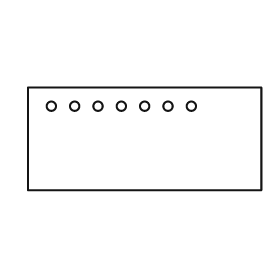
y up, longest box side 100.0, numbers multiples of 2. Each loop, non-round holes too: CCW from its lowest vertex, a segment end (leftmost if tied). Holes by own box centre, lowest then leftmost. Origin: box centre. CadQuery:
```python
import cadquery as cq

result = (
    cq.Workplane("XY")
    .moveTo(-50.0, -22.0)
    .lineTo(50.0, -22.0)
    .lineTo(50.0, 22.0)
    .lineTo(-50.0, 22.0)
    .close()
    .moveTo(-40.0, 14.0)
    .circle(2.0)
    .moveTo(-30.0, 14.0)
    .circle(2.0)
    .moveTo(-20.0, 14.0)
    .circle(2.0)
    .moveTo(-10.0, 14.0)
    .circle(2.0)
    .moveTo(0.0, 14.0)
    .circle(2.0)
    .moveTo(10.0, 14.0)
    .circle(2.0)
    .moveTo(20.0, 14.0)
    .circle(2.0)
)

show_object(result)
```